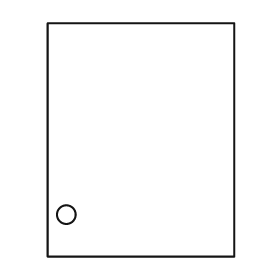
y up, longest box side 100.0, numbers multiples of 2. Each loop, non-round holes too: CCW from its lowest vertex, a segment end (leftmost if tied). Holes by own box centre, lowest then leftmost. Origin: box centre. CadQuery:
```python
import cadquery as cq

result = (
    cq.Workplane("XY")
    .moveTo(-40.0, -50.0)
    .lineTo(40.0, -50.0)
    .lineTo(40.0, 50.0)
    .lineTo(-40.0, 50.0)
    .close()
    .moveTo(-32.0, -32.0)
    .circle(4.0)
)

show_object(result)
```